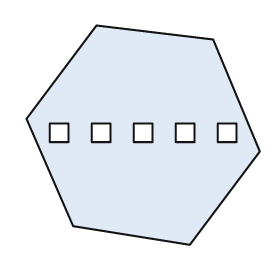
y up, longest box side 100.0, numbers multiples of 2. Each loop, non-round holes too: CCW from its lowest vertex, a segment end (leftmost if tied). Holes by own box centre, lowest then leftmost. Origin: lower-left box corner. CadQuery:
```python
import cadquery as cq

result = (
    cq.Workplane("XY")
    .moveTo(70.0, 0.0)
    .lineTo(100.0, 40.0)
    .lineTo(80.0, 88.0)
    .lineTo(30.0, 94.0)
    .lineTo(0.0, 54.0)
    .lineTo(20.0, 8.0)
    .close()
    .moveTo(10.0, 44.0)
    .lineTo(18.0, 44.0)
    .lineTo(18.0, 52.0)
    .lineTo(10.0, 52.0)
    .close()
    .moveTo(28.0, 44.0)
    .lineTo(36.0, 44.0)
    .lineTo(36.0, 52.0)
    .lineTo(28.0, 52.0)
    .close()
    .moveTo(46.0, 44.0)
    .lineTo(54.0, 44.0)
    .lineTo(54.0, 52.0)
    .lineTo(46.0, 52.0)
    .close()
    .moveTo(64.0, 44.0)
    .lineTo(72.0, 44.0)
    .lineTo(72.0, 52.0)
    .lineTo(64.0, 52.0)
    .close()
    .moveTo(82.0, 44.0)
    .lineTo(90.0, 44.0)
    .lineTo(90.0, 52.0)
    .lineTo(82.0, 52.0)
    .close()
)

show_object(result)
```